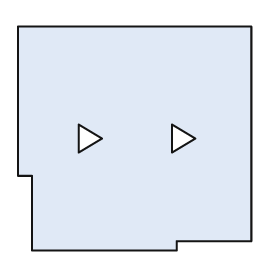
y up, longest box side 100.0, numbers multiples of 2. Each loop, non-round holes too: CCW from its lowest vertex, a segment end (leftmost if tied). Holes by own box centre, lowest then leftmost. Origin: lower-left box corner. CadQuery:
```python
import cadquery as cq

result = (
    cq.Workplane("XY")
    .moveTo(6.0, 0.0)
    .lineTo(68.0, 0.0)
    .lineTo(68.0, 4.0)
    .lineTo(100.0, 4.0)
    .lineTo(100.0, 96.0)
    .lineTo(0.0, 96.0)
    .lineTo(0.0, 32.0)
    .lineTo(6.0, 32.0)
    .close()
    .moveTo(26.0, 42.0)
    .lineTo(36.0, 48.0)
    .lineTo(26.0, 54.0)
    .close()
    .moveTo(66.0, 42.0)
    .lineTo(76.0, 48.0)
    .lineTo(66.0, 54.0)
    .close()
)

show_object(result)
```